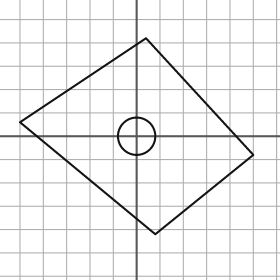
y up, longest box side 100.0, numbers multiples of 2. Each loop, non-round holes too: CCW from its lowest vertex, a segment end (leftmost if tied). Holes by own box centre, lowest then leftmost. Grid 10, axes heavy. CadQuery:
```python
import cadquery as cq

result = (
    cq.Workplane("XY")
    .moveTo(8.0, -42.0)
    .lineTo(50.0, -8.0)
    .lineTo(4.0, 42.0)
    .lineTo(-50.0, 6.0)
    .close()
    .moveTo(0.0, 0.0)
    .circle(8.0)
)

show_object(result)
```